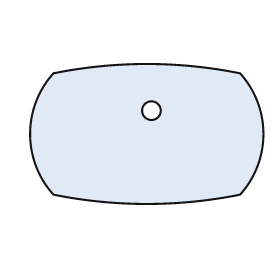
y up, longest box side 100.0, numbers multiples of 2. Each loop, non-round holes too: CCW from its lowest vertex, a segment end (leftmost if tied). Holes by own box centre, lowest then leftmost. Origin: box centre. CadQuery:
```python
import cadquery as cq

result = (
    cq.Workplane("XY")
    .moveTo(-40.0, -26.0)
    .threePointArc((0.0, -30.0), (40.0, -26.0))
    .threePointArc((50.0, 0.0), (40.0, 26.0))
    .threePointArc((0.0, 30.0), (-40.0, 26.0))
    .threePointArc((-50.0, 0.0), (-40.0, -26.0))
    .close()
    .moveTo(2.0, 10.0)
    .circle(4.0)
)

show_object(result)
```